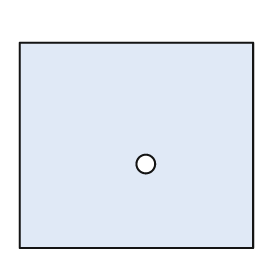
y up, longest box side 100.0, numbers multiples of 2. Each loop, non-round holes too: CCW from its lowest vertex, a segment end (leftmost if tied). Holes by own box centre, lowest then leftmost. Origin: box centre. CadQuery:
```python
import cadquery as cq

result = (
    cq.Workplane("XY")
    .moveTo(-50.0, -44.0)
    .lineTo(50.0, -44.0)
    .lineTo(50.0, 44.0)
    .lineTo(-50.0, 44.0)
    .close()
    .moveTo(4.0, -8.0)
    .circle(4.0)
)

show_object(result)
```